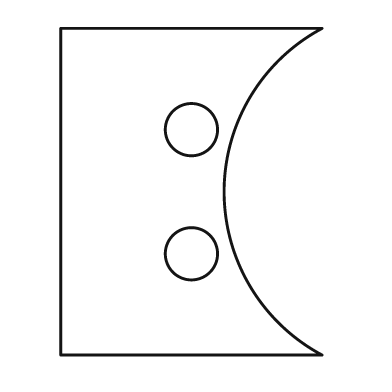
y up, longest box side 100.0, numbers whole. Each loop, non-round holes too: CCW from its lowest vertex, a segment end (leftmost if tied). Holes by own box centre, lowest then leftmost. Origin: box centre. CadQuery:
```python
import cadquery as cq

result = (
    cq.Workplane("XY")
    .moveTo(-40.0, -50.0)
    .lineTo(40.0, -50.0)
    .threePointArc((10.0, 0.0), (40.0, 50.0))
    .lineTo(-40.0, 50.0)
    .close()
    .moveTo(0.0, -19.0)
    .circle(8.0)
    .moveTo(0.0, 19.0)
    .circle(8.0)
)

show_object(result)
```